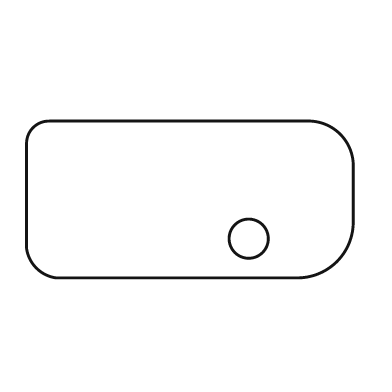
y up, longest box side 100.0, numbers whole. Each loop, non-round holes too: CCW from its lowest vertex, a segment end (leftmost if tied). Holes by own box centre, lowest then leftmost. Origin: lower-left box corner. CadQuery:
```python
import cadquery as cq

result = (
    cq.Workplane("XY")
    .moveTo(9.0, 0.0)
    .lineTo(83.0, 0.0)
    .threePointArc((95.0, 5.0), (100.0, 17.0))
    .lineTo(100.0, 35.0)
    .threePointArc((96.0, 44.0), (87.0, 48.0))
    .lineTo(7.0, 48.0)
    .threePointArc((2.0, 46.0), (0.0, 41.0))
    .lineTo(0.0, 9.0)
    .threePointArc((3.0, 3.0), (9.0, 0.0))
    .close()
    .moveTo(68.0, 12.0)
    .circle(6.0)
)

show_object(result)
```